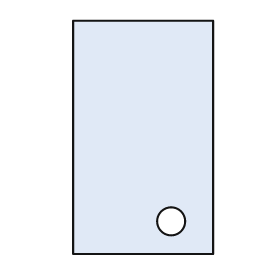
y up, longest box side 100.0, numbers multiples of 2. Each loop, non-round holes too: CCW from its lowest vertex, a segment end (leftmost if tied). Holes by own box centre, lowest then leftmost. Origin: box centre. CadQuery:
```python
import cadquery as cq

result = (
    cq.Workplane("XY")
    .moveTo(-30.0, -50.0)
    .lineTo(30.0, -50.0)
    .lineTo(30.0, 50.0)
    .lineTo(-30.0, 50.0)
    .close()
    .moveTo(12.0, -36.0)
    .circle(6.0)
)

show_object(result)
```